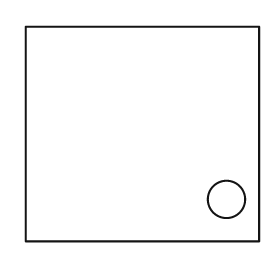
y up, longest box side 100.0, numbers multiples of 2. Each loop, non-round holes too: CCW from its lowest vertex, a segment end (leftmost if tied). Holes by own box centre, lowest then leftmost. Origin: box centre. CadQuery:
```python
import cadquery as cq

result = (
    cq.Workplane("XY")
    .moveTo(-50.0, -46.0)
    .lineTo(50.0, -46.0)
    .lineTo(50.0, 46.0)
    .lineTo(-50.0, 46.0)
    .close()
    .moveTo(36.0, -28.0)
    .circle(8.0)
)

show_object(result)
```